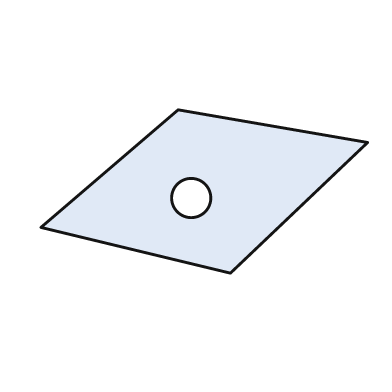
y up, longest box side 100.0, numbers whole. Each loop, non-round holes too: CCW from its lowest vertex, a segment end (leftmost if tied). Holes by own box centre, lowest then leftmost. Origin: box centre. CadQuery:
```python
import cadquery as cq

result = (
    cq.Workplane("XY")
    .moveTo(8.0, -25.0)
    .lineTo(50.0, 15.0)
    .lineTo(-8.0, 25.0)
    .lineTo(-50.0, -11.0)
    .close()
    .moveTo(-4.0, -2.0)
    .circle(6.0)
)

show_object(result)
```